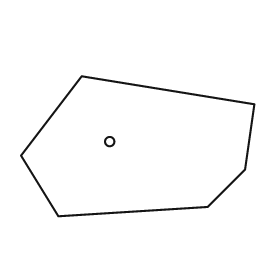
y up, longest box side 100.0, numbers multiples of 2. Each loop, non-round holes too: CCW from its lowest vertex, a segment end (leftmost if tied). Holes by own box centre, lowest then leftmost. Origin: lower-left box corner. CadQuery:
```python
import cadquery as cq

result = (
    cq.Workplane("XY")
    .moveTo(16.0, 0.0)
    .lineTo(80.0, 4.0)
    .lineTo(96.0, 20.0)
    .lineTo(100.0, 48.0)
    .lineTo(26.0, 60.0)
    .lineTo(0.0, 26.0)
    .close()
    .moveTo(38.0, 32.0)
    .circle(2.0)
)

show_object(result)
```